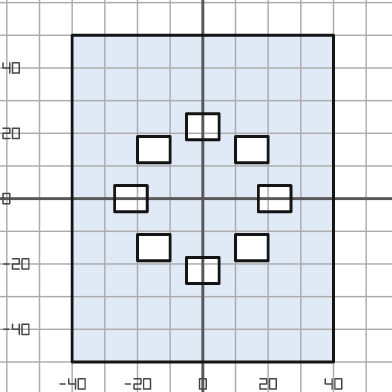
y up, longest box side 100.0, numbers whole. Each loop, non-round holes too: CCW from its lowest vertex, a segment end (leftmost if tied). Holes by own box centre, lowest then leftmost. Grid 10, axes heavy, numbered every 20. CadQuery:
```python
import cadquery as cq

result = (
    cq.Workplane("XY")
    .moveTo(-40.0, -50.0)
    .lineTo(40.0, -50.0)
    .lineTo(40.0, 50.0)
    .lineTo(-40.0, 50.0)
    .close()
    .moveTo(-5.0, -26.0)
    .lineTo(5.0, -26.0)
    .lineTo(5.0, -18.0)
    .lineTo(-5.0, -18.0)
    .close()
    .moveTo(-20.0, -19.0)
    .lineTo(-10.0, -19.0)
    .lineTo(-10.0, -11.0)
    .lineTo(-20.0, -11.0)
    .close()
    .moveTo(10.0, -19.0)
    .lineTo(20.0, -19.0)
    .lineTo(20.0, -11.0)
    .lineTo(10.0, -11.0)
    .close()
    .moveTo(-27.0, -4.0)
    .lineTo(-17.0, -4.0)
    .lineTo(-17.0, 4.0)
    .lineTo(-27.0, 4.0)
    .close()
    .moveTo(17.0, -4.0)
    .lineTo(27.0, -4.0)
    .lineTo(27.0, 4.0)
    .lineTo(17.0, 4.0)
    .close()
    .moveTo(-20.0, 11.0)
    .lineTo(-10.0, 11.0)
    .lineTo(-10.0, 19.0)
    .lineTo(-20.0, 19.0)
    .close()
    .moveTo(10.0, 11.0)
    .lineTo(20.0, 11.0)
    .lineTo(20.0, 19.0)
    .lineTo(10.0, 19.0)
    .close()
    .moveTo(-5.0, 18.0)
    .lineTo(5.0, 18.0)
    .lineTo(5.0, 26.0)
    .lineTo(-5.0, 26.0)
    .close()
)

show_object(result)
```